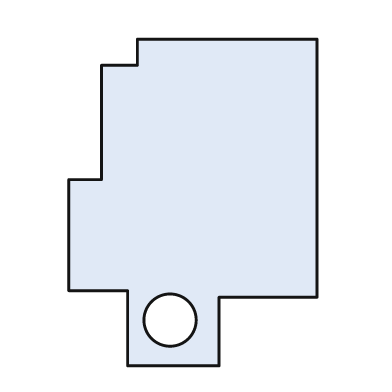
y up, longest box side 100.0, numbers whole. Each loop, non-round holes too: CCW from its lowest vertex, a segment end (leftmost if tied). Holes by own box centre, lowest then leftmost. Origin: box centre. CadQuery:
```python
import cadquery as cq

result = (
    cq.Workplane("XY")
    .moveTo(-20.0, -50.0)
    .lineTo(8.0, -50.0)
    .lineTo(8.0, -29.0)
    .lineTo(38.0, -29.0)
    .lineTo(38.0, 50.0)
    .lineTo(-17.0, 50.0)
    .lineTo(-17.0, 42.0)
    .lineTo(-28.0, 42.0)
    .lineTo(-28.0, 7.0)
    .lineTo(-38.0, 7.0)
    .lineTo(-38.0, -27.0)
    .lineTo(-20.0, -27.0)
    .close()
    .moveTo(-7.0, -36.0)
    .circle(8.0)
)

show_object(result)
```